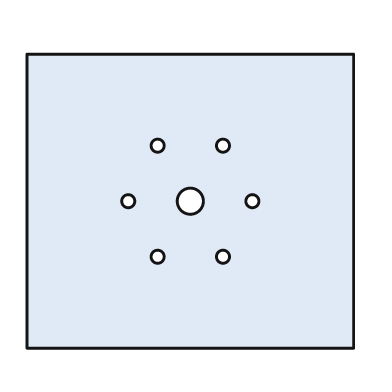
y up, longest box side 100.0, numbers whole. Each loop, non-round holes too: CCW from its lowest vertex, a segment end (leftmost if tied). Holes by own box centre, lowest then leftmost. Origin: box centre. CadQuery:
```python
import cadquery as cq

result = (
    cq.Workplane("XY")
    .moveTo(-50.0, -45.0)
    .lineTo(50.0, -45.0)
    .lineTo(50.0, 45.0)
    .lineTo(-50.0, 45.0)
    .close()
    .moveTo(-10.0, -17.0)
    .circle(2.0)
    .moveTo(10.0, -17.0)
    .circle(2.0)
    .moveTo(-19.0, 0.0)
    .circle(2.0)
    .moveTo(0.0, 0.0)
    .circle(4.0)
    .moveTo(19.0, 0.0)
    .circle(2.0)
    .moveTo(-10.0, 17.0)
    .circle(2.0)
    .moveTo(10.0, 17.0)
    .circle(2.0)
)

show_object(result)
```